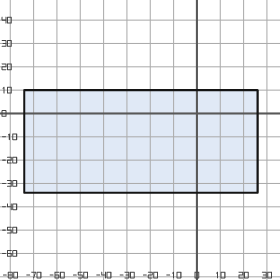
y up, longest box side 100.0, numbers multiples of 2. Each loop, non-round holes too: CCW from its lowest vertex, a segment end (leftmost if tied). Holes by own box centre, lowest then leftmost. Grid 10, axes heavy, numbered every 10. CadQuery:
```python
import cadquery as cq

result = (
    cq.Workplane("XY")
    .moveTo(-74.0, -34.0)
    .lineTo(26.0, -34.0)
    .lineTo(26.0, 10.0)
    .lineTo(-74.0, 10.0)
    .close()
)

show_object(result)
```